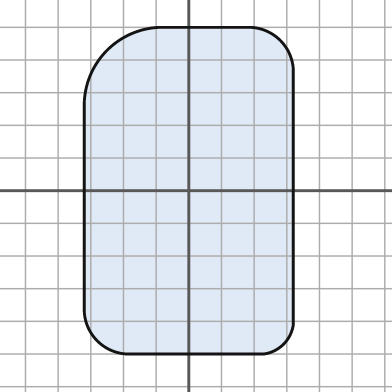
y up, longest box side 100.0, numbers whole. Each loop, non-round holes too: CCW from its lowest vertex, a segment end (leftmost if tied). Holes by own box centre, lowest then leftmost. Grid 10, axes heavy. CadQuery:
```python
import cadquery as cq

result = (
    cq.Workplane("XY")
    .moveTo(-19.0, -50.0)
    .lineTo(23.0, -50.0)
    .threePointArc((29.0, -47.0), (32.0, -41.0))
    .lineTo(32.0, 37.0)
    .threePointArc((28.0, 46.0), (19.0, 50.0))
    .lineTo(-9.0, 50.0)
    .threePointArc((-25.0, 43.0), (-32.0, 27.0))
    .lineTo(-32.0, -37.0)
    .threePointArc((-28.0, -46.0), (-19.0, -50.0))
    .close()
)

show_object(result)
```